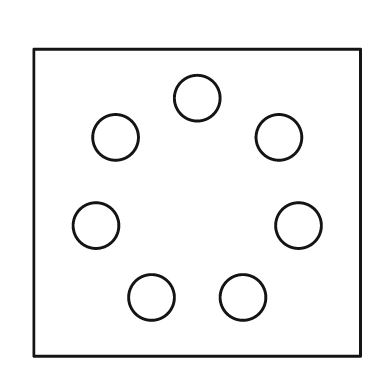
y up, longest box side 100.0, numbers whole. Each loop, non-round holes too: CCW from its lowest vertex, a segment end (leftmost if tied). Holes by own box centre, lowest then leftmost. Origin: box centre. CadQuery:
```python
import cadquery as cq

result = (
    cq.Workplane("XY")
    .moveTo(-50.0, -47.0)
    .lineTo(50.0, -47.0)
    .lineTo(50.0, 47.0)
    .lineTo(-50.0, 47.0)
    .close()
    .moveTo(-14.0, -29.0)
    .circle(7.0)
    .moveTo(14.0, -29.0)
    .circle(7.0)
    .moveTo(-31.0, -7.0)
    .circle(7.0)
    .moveTo(31.0, -7.0)
    .circle(7.0)
    .moveTo(-25.0, 20.0)
    .circle(7.0)
    .moveTo(25.0, 20.0)
    .circle(7.0)
    .moveTo(0.0, 32.0)
    .circle(7.0)
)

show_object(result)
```